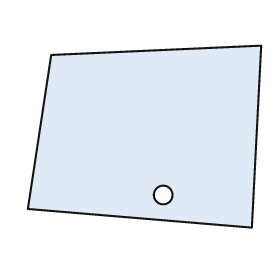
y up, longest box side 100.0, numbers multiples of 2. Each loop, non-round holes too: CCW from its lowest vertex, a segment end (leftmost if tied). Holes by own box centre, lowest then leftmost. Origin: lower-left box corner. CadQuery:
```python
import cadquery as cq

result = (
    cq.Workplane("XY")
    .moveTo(96.0, 0.0)
    .lineTo(100.0, 78.0)
    .lineTo(10.0, 74.0)
    .lineTo(0.0, 8.0)
    .close()
    .moveTo(58.0, 14.0)
    .circle(4.0)
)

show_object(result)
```